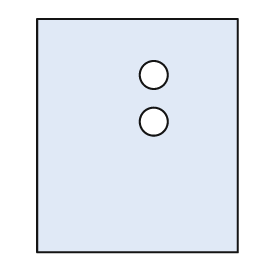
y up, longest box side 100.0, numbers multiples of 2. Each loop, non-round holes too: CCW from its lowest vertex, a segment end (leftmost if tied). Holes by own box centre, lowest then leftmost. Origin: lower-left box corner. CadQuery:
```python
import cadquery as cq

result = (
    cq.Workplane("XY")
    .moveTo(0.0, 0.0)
    .lineTo(86.0, 0.0)
    .lineTo(86.0, 100.0)
    .lineTo(0.0, 100.0)
    .close()
    .moveTo(50.0, 56.0)
    .circle(6.0)
    .moveTo(50.0, 76.0)
    .circle(6.0)
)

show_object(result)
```